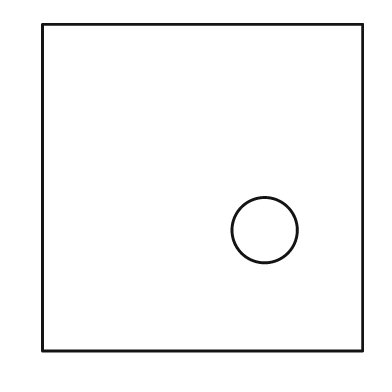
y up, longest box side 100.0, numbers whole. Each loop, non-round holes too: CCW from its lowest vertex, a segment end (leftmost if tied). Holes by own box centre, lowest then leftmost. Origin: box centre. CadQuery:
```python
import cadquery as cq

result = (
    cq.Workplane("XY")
    .moveTo(-49.0, -50.0)
    .lineTo(49.0, -50.0)
    .lineTo(49.0, 50.0)
    .lineTo(-49.0, 50.0)
    .close()
    .moveTo(19.0, -13.0)
    .circle(10.0)
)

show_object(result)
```